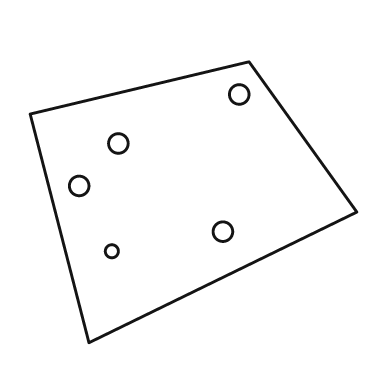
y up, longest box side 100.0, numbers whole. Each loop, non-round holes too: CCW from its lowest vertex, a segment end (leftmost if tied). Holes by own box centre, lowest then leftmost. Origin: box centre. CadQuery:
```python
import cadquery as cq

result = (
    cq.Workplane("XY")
    .moveTo(-32.0, -43.0)
    .lineTo(50.0, -3.0)
    .lineTo(17.0, 43.0)
    .lineTo(-50.0, 27.0)
    .close()
    .moveTo(-25.0, -15.0)
    .circle(2.0)
    .moveTo(9.0, -9.0)
    .circle(3.0)
    .moveTo(-35.0, 5.0)
    .circle(3.0)
    .moveTo(-23.0, 18.0)
    .circle(3.0)
    .moveTo(14.0, 33.0)
    .circle(3.0)
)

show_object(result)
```